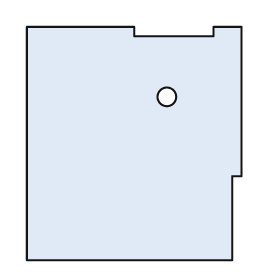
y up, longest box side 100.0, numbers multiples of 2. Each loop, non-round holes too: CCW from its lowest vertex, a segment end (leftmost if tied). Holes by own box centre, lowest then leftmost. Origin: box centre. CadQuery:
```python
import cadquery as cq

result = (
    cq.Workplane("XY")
    .moveTo(-46.0, -50.0)
    .lineTo(42.0, -50.0)
    .lineTo(42.0, -14.0)
    .lineTo(46.0, -14.0)
    .lineTo(46.0, 50.0)
    .lineTo(34.0, 50.0)
    .lineTo(34.0, 46.0)
    .lineTo(0.0, 46.0)
    .lineTo(0.0, 50.0)
    .lineTo(-46.0, 50.0)
    .close()
    .moveTo(14.0, 20.0)
    .circle(4.0)
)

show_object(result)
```